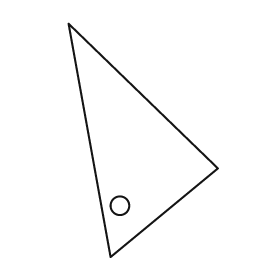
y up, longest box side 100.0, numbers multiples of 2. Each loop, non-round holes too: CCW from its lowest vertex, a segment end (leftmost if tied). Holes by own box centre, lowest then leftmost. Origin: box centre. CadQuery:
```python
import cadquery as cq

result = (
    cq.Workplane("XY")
    .moveTo(-14.0, -50.0)
    .lineTo(32.0, -12.0)
    .lineTo(-32.0, 50.0)
    .close()
    .moveTo(-10.0, -28.0)
    .circle(4.0)
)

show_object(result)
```